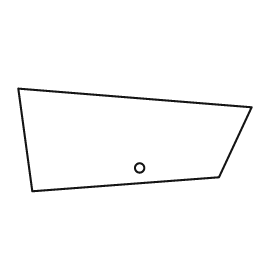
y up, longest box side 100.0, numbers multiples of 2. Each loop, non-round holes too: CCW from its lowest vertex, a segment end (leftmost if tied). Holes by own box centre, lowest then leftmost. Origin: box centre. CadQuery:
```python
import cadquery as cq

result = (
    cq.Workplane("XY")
    .moveTo(-44.0, -22.0)
    .lineTo(36.0, -16.0)
    .lineTo(50.0, 14.0)
    .lineTo(-50.0, 22.0)
    .close()
    .moveTo(2.0, -12.0)
    .circle(2.0)
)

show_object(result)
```